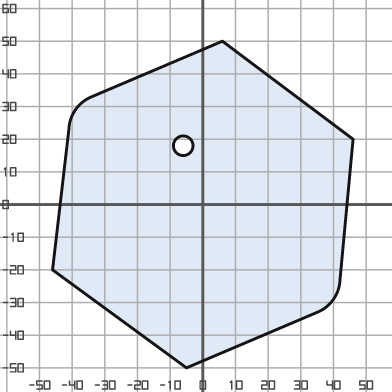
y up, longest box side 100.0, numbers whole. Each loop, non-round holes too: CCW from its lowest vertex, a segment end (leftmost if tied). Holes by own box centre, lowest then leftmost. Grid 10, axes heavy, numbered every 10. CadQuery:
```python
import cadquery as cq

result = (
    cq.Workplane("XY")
    .moveTo(-5.0, -50.0)
    .lineTo(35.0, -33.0)
    .threePointArc((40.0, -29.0), (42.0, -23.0))
    .lineTo(46.0, 20.0)
    .lineTo(6.0, 50.0)
    .lineTo(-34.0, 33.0)
    .threePointArc((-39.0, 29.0), (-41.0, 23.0))
    .lineTo(-46.0, -20.0)
    .close()
    .moveTo(-6.0, 18.0)
    .circle(3.0)
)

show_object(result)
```